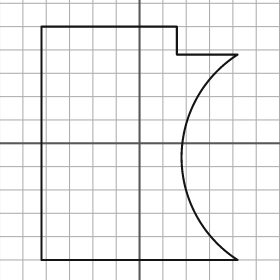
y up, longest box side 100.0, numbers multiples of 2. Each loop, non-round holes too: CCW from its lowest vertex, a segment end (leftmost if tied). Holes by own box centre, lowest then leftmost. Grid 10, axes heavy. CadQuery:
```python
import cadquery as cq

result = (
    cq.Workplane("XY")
    .moveTo(-42.0, -50.0)
    .lineTo(42.0, -50.0)
    .threePointArc((18.0, -6.0), (42.0, 38.0))
    .lineTo(16.0, 38.0)
    .lineTo(16.0, 50.0)
    .lineTo(-42.0, 50.0)
    .close()
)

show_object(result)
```